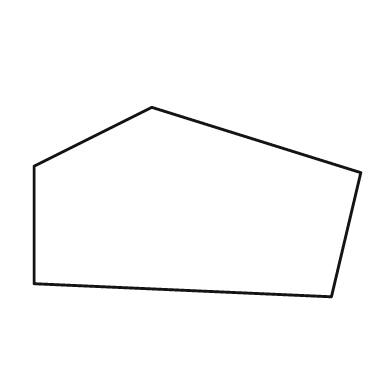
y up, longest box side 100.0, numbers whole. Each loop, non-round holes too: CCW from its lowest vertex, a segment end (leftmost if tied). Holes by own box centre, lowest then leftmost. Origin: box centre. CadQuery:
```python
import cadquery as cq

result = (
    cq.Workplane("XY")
    .moveTo(41.0, -29.0)
    .lineTo(50.0, 9.0)
    .lineTo(-14.0, 29.0)
    .lineTo(-50.0, 11.0)
    .lineTo(-50.0, -25.0)
    .close()
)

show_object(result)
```